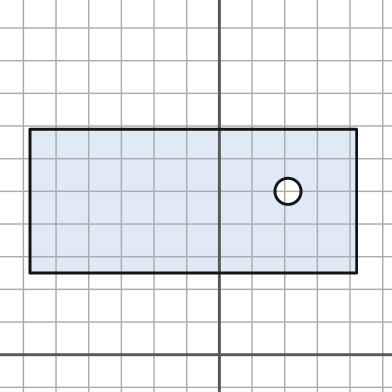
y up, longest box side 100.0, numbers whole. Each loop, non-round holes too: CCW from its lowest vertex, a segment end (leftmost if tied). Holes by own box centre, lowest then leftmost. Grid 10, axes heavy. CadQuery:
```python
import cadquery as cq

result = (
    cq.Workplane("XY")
    .moveTo(-58.0, 25.0)
    .lineTo(42.0, 25.0)
    .lineTo(42.0, 69.0)
    .lineTo(-58.0, 69.0)
    .close()
    .moveTo(21.0, 50.0)
    .circle(4.0)
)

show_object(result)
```